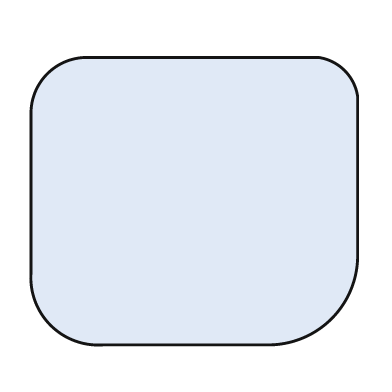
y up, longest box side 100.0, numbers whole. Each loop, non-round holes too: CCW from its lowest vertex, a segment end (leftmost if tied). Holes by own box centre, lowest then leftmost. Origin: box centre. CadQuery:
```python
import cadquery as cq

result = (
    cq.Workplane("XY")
    .moveTo(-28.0, -44.0)
    .lineTo(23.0, -44.0)
    .threePointArc((42.0, -36.0), (50.0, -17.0))
    .lineTo(50.0, 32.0)
    .threePointArc((46.0, 40.0), (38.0, 44.0))
    .lineTo(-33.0, 44.0)
    .threePointArc((-45.0, 39.0), (-50.0, 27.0))
    .lineTo(-50.0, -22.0)
    .threePointArc((-44.0, -38.0), (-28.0, -44.0))
    .close()
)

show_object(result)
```